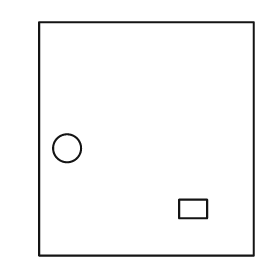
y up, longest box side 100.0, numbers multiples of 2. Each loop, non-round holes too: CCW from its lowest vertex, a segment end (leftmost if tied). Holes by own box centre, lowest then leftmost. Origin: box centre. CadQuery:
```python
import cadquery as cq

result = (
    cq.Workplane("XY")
    .moveTo(-46.0, -50.0)
    .lineTo(46.0, -50.0)
    .lineTo(46.0, 50.0)
    .lineTo(-46.0, 50.0)
    .close()
    .moveTo(14.0, -34.0)
    .lineTo(26.0, -34.0)
    .lineTo(26.0, -26.0)
    .lineTo(14.0, -26.0)
    .close()
    .moveTo(-34.0, -4.0)
    .circle(6.0)
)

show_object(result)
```